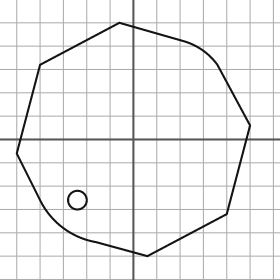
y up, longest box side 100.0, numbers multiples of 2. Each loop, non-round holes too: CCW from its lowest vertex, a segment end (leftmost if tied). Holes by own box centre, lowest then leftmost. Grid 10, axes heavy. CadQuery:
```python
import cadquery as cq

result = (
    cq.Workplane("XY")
    .moveTo(6.0, -50.0)
    .lineTo(40.0, -32.0)
    .lineTo(50.0, 6.0)
    .lineTo(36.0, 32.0)
    .threePointArc((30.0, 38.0), (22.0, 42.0))
    .lineTo(-6.0, 50.0)
    .lineTo(-40.0, 32.0)
    .lineTo(-50.0, -6.0)
    .lineTo(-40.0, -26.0)
    .threePointArc((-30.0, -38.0), (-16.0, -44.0))
    .close()
    .moveTo(-24.0, -26.0)
    .circle(4.0)
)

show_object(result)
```